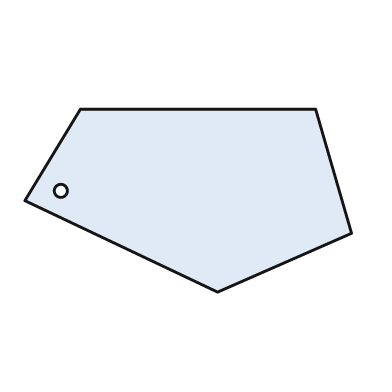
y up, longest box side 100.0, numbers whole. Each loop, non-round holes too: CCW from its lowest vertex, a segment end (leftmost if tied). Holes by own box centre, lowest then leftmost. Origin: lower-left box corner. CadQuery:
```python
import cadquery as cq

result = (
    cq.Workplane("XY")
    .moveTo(59.0, 0.0)
    .lineTo(100.0, 18.0)
    .lineTo(89.0, 56.0)
    .lineTo(17.0, 56.0)
    .lineTo(0.0, 28.0)
    .close()
    .moveTo(11.0, 31.0)
    .circle(2.0)
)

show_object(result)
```